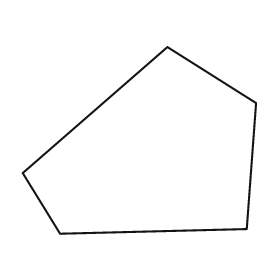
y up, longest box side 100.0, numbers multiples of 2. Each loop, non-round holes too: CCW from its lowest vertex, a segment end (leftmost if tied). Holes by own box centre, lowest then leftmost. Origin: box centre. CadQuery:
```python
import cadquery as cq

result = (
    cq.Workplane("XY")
    .moveTo(-34.0, -40.0)
    .lineTo(46.0, -38.0)
    .lineTo(50.0, 16.0)
    .lineTo(12.0, 40.0)
    .lineTo(-50.0, -14.0)
    .close()
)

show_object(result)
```